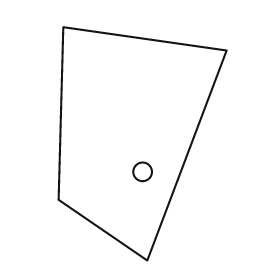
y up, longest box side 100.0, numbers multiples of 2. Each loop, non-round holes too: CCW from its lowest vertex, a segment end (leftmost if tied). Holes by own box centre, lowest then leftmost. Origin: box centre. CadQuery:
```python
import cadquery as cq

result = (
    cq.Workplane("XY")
    .moveTo(2.0, -50.0)
    .lineTo(36.0, 40.0)
    .lineTo(-34.0, 50.0)
    .lineTo(-36.0, -24.0)
    .close()
    .moveTo(0.0, -12.0)
    .circle(4.0)
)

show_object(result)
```